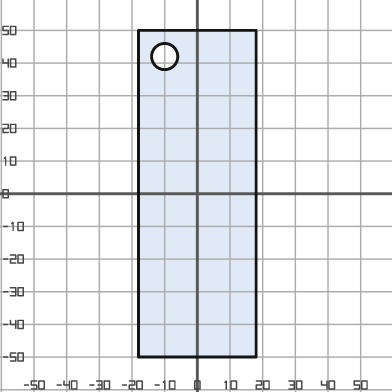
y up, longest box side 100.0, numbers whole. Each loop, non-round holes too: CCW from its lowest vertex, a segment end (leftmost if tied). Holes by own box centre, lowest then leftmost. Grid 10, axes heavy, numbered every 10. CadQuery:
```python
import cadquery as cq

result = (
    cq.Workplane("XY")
    .moveTo(-18.0, -50.0)
    .lineTo(18.0, -50.0)
    .lineTo(18.0, 50.0)
    .lineTo(-18.0, 50.0)
    .close()
    .moveTo(-10.0, 42.0)
    .circle(4.0)
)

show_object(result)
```